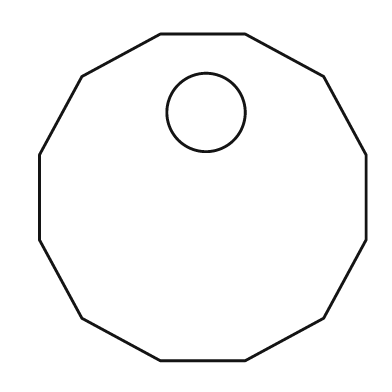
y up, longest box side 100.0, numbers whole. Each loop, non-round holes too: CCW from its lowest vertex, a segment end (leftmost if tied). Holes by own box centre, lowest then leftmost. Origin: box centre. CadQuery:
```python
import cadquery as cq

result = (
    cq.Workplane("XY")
    .moveTo(-13.0, -50.0)
    .lineTo(13.0, -50.0)
    .lineTo(37.0, -37.0)
    .lineTo(50.0, -13.0)
    .lineTo(50.0, 13.0)
    .lineTo(37.0, 37.0)
    .lineTo(13.0, 50.0)
    .lineTo(-13.0, 50.0)
    .lineTo(-37.0, 37.0)
    .lineTo(-50.0, 13.0)
    .lineTo(-50.0, -13.0)
    .lineTo(-37.0, -37.0)
    .close()
    .moveTo(1.0, 26.0)
    .circle(12.0)
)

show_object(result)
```